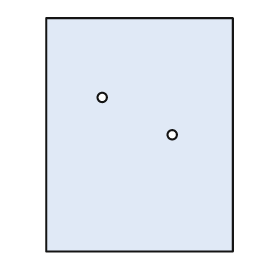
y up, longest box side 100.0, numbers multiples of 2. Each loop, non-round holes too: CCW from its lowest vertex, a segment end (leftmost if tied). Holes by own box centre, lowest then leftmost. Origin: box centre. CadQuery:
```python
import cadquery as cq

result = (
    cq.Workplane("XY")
    .moveTo(-40.0, -50.0)
    .lineTo(40.0, -50.0)
    .lineTo(40.0, 50.0)
    .lineTo(-40.0, 50.0)
    .close()
    .moveTo(14.0, 0.0)
    .circle(2.0)
    .moveTo(-16.0, 16.0)
    .circle(2.0)
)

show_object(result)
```